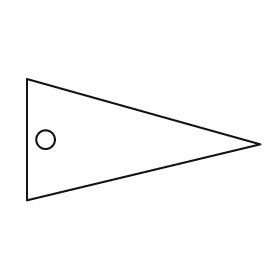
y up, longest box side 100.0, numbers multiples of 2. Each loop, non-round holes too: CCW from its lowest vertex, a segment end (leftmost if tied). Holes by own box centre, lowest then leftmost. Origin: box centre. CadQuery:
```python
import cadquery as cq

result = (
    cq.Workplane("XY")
    .moveTo(-50.0, -26.0)
    .lineTo(50.0, -2.0)
    .lineTo(-50.0, 26.0)
    .close()
    .moveTo(-42.0, 0.0)
    .circle(4.0)
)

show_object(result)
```